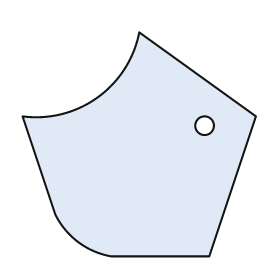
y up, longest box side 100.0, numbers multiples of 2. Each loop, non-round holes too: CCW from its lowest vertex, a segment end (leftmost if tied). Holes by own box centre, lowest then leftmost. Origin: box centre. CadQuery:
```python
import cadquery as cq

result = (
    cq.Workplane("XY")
    .moveTo(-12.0, -48.0)
    .lineTo(30.0, -48.0)
    .lineTo(50.0, 12.0)
    .lineTo(0.0, 48.0)
    .threePointArc((-18.0, 20.0), (-50.0, 12.0))
    .lineTo(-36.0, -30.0)
    .threePointArc((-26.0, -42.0), (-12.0, -48.0))
    .close()
    .moveTo(28.0, 8.0)
    .circle(4.0)
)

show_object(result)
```